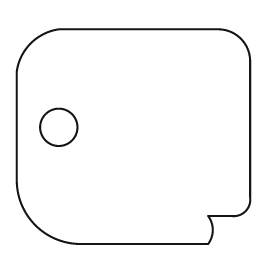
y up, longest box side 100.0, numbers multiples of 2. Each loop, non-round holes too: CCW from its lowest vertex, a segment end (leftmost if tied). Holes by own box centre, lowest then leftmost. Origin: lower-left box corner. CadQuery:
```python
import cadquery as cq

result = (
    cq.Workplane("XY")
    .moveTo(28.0, 0.0)
    .lineTo(82.0, 0.0)
    .threePointArc((84.0, 6.0), (82.0, 12.0))
    .lineTo(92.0, 12.0)
    .threePointArc((98.0, 14.0), (100.0, 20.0))
    .lineTo(100.0, 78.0)
    .threePointArc((96.0, 88.0), (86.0, 92.0))
    .lineTo(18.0, 92.0)
    .threePointArc((6.0, 86.0), (0.0, 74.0))
    .lineTo(0.0, 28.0)
    .threePointArc((8.0, 8.0), (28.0, 0.0))
    .close()
    .moveTo(18.0, 50.0)
    .circle(8.0)
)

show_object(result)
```